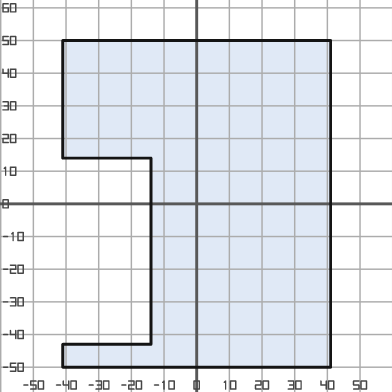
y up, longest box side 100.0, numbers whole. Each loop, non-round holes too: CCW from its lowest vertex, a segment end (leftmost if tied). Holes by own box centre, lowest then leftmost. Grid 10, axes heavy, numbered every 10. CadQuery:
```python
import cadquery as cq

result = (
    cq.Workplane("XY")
    .moveTo(-41.0, -50.0)
    .lineTo(41.0, -50.0)
    .lineTo(41.0, 50.0)
    .lineTo(-41.0, 50.0)
    .lineTo(-41.0, 14.0)
    .lineTo(-14.0, 14.0)
    .lineTo(-14.0, -43.0)
    .lineTo(-41.0, -43.0)
    .close()
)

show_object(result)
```